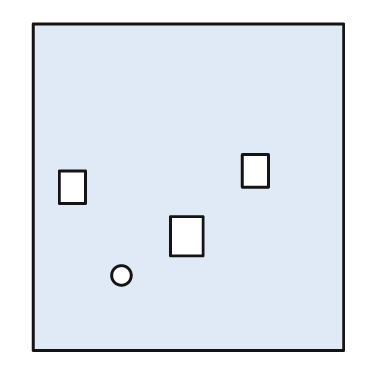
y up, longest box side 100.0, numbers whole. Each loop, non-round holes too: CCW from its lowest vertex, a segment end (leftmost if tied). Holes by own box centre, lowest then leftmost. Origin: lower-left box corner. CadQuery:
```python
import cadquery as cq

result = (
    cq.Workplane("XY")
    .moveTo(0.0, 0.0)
    .lineTo(95.0, 0.0)
    .lineTo(95.0, 100.0)
    .lineTo(0.0, 100.0)
    .close()
    .moveTo(27.0, 23.0)
    .circle(3.0)
    .moveTo(42.0, 29.0)
    .lineTo(52.0, 29.0)
    .lineTo(52.0, 41.0)
    .lineTo(42.0, 41.0)
    .close()
    .moveTo(8.0, 45.0)
    .lineTo(16.0, 45.0)
    .lineTo(16.0, 55.0)
    .lineTo(8.0, 55.0)
    .close()
    .moveTo(64.0, 50.0)
    .lineTo(72.0, 50.0)
    .lineTo(72.0, 60.0)
    .lineTo(64.0, 60.0)
    .close()
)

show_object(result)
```